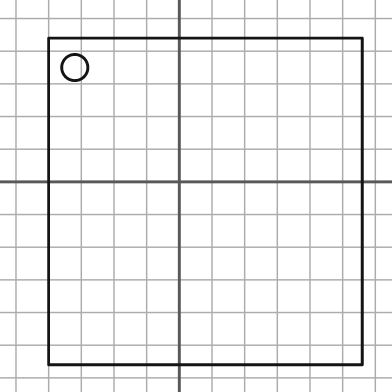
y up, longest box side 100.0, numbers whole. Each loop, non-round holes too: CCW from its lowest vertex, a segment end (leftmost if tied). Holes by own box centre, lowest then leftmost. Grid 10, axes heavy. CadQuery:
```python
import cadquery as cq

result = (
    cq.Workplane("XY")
    .moveTo(-40.0, -56.0)
    .lineTo(56.0, -56.0)
    .lineTo(56.0, 44.0)
    .lineTo(-40.0, 44.0)
    .close()
    .moveTo(-32.0, 35.0)
    .circle(4.0)
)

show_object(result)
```